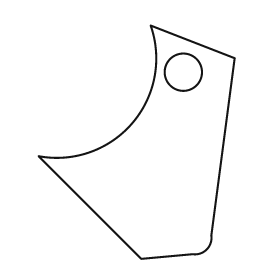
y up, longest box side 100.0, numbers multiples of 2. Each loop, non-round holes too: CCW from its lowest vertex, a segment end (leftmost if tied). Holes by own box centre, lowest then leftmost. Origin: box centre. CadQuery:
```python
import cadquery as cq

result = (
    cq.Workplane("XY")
    .moveTo(2.0, -50.0)
    .lineTo(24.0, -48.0)
    .threePointArc((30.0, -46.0), (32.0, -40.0))
    .lineTo(42.0, 36.0)
    .lineTo(6.0, 50.0)
    .threePointArc((-2.0, 8.0), (-42.0, -6.0))
    .close()
    .moveTo(20.0, 30.0)
    .circle(8.0)
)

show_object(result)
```